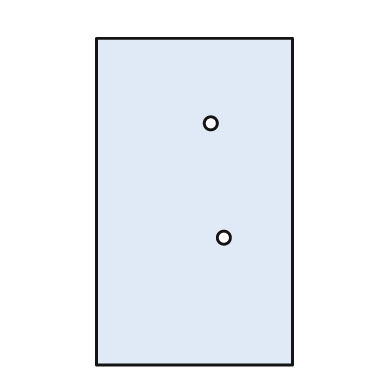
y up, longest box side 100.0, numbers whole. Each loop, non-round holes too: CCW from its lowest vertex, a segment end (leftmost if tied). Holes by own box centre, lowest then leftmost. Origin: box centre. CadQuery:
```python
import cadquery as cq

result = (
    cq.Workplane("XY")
    .moveTo(-30.0, -50.0)
    .lineTo(30.0, -50.0)
    .lineTo(30.0, 50.0)
    .lineTo(-30.0, 50.0)
    .close()
    .moveTo(9.0, -11.0)
    .circle(2.0)
    .moveTo(5.0, 24.0)
    .circle(2.0)
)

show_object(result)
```